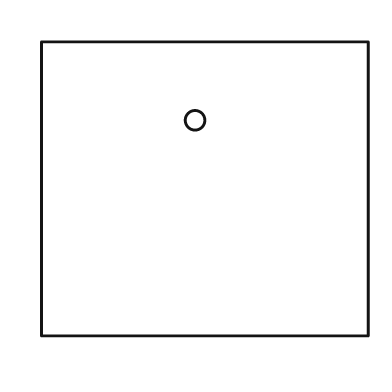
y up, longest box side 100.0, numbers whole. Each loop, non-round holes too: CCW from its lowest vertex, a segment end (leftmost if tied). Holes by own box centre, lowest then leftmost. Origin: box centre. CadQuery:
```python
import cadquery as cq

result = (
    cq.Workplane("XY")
    .moveTo(-50.0, -45.0)
    .lineTo(50.0, -45.0)
    .lineTo(50.0, 45.0)
    .lineTo(-50.0, 45.0)
    .close()
    .moveTo(-3.0, 21.0)
    .circle(3.0)
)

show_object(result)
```